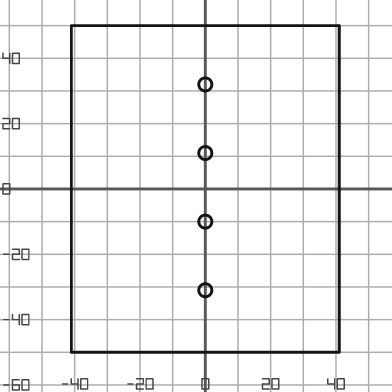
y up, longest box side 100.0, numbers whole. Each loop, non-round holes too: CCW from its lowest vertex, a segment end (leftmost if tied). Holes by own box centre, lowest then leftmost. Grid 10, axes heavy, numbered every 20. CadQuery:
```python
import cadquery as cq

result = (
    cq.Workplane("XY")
    .moveTo(-41.0, -50.0)
    .lineTo(41.0, -50.0)
    .lineTo(41.0, 50.0)
    .lineTo(-41.0, 50.0)
    .close()
    .moveTo(0.0, -31.0)
    .circle(2.0)
    .moveTo(0.0, -10.0)
    .circle(2.0)
    .moveTo(0.0, 11.0)
    .circle(2.0)
    .moveTo(0.0, 32.0)
    .circle(2.0)
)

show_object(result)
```